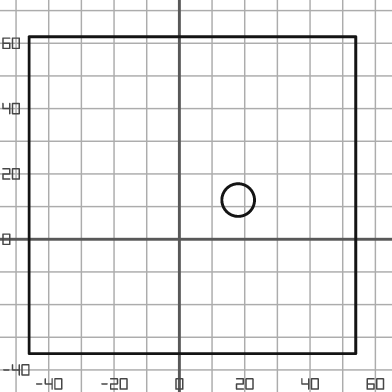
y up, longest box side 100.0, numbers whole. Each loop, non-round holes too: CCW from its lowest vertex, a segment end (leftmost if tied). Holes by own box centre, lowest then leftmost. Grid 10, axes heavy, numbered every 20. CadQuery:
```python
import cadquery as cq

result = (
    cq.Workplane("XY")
    .moveTo(-46.0, -35.0)
    .lineTo(54.0, -35.0)
    .lineTo(54.0, 62.0)
    .lineTo(-46.0, 62.0)
    .close()
    .moveTo(18.0, 12.0)
    .circle(5.0)
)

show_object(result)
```